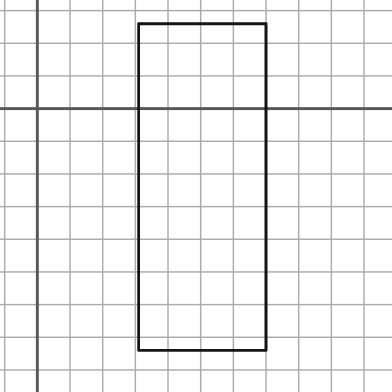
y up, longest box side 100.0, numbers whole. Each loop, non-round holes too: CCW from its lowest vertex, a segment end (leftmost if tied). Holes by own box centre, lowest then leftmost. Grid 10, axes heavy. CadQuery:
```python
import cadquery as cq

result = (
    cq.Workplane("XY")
    .moveTo(31.0, -74.0)
    .lineTo(70.0, -74.0)
    .lineTo(70.0, 26.0)
    .lineTo(31.0, 26.0)
    .close()
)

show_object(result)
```